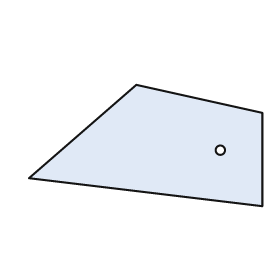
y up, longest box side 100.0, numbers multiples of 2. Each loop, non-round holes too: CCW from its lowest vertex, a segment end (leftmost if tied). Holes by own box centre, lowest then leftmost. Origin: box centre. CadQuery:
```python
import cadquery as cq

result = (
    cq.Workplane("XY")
    .moveTo(50.0, -26.0)
    .lineTo(50.0, 14.0)
    .lineTo(-4.0, 26.0)
    .lineTo(-50.0, -14.0)
    .close()
    .moveTo(32.0, -2.0)
    .circle(2.0)
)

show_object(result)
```